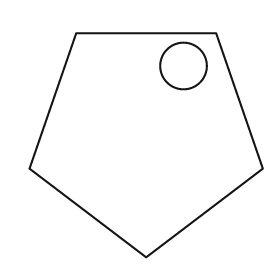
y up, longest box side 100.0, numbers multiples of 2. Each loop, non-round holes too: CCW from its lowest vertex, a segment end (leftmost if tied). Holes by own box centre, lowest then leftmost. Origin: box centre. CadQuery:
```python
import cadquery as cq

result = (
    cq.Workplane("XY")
    .moveTo(0.0, -48.0)
    .lineTo(50.0, -10.0)
    .lineTo(30.0, 48.0)
    .lineTo(-30.0, 48.0)
    .lineTo(-50.0, -10.0)
    .close()
    .moveTo(16.0, 34.0)
    .circle(10.0)
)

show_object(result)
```